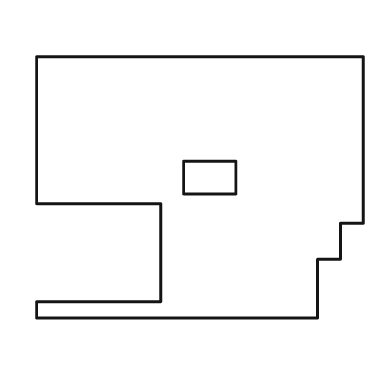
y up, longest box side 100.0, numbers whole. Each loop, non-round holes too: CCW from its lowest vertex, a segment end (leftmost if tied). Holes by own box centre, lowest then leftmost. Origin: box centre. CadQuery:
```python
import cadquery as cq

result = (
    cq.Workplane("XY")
    .moveTo(-50.0, -40.0)
    .lineTo(36.0, -40.0)
    .lineTo(36.0, -22.0)
    .lineTo(43.0, -22.0)
    .lineTo(43.0, -11.0)
    .lineTo(50.0, -11.0)
    .lineTo(50.0, 40.0)
    .lineTo(-50.0, 40.0)
    .lineTo(-50.0, -5.0)
    .lineTo(-12.0, -5.0)
    .lineTo(-12.0, -35.0)
    .lineTo(-50.0, -35.0)
    .close()
    .moveTo(-5.0, -2.0)
    .lineTo(11.0, -2.0)
    .lineTo(11.0, 8.0)
    .lineTo(-5.0, 8.0)
    .close()
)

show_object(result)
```